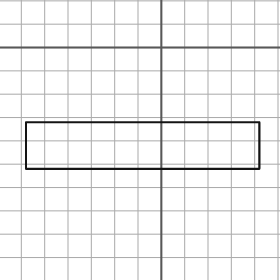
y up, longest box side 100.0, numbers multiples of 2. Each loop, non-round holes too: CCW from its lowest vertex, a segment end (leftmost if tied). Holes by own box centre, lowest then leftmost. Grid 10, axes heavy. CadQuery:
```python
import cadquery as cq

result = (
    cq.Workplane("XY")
    .moveTo(-58.0, -52.0)
    .lineTo(42.0, -52.0)
    .lineTo(42.0, -32.0)
    .lineTo(-58.0, -32.0)
    .close()
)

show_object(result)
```